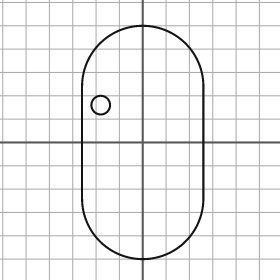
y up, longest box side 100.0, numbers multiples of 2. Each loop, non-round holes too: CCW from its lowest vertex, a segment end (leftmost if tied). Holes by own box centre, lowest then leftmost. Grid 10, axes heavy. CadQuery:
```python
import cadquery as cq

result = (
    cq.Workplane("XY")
    .moveTo(-26.0, -24.0)
    .threePointArc((0.0, -50.0), (26.0, -24.0))
    .lineTo(26.0, 24.0)
    .threePointArc((0.0, 50.0), (-26.0, 24.0))
    .close()
    .moveTo(-18.0, 16.0)
    .circle(4.0)
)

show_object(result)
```